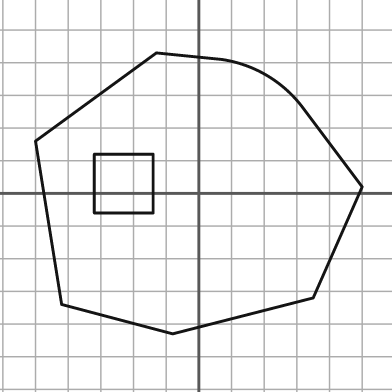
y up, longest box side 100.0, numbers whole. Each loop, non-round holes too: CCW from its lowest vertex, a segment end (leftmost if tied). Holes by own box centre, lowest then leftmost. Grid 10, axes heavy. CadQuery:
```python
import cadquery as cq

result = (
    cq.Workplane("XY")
    .moveTo(-8.0, -43.0)
    .lineTo(35.0, -32.0)
    .lineTo(50.0, 2.0)
    .lineTo(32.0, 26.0)
    .threePointArc((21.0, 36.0), (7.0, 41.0))
    .lineTo(-13.0, 43.0)
    .lineTo(-50.0, 16.0)
    .lineTo(-42.0, -34.0)
    .close()
    .moveTo(-32.0, -6.0)
    .lineTo(-14.0, -6.0)
    .lineTo(-14.0, 12.0)
    .lineTo(-32.0, 12.0)
    .close()
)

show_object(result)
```